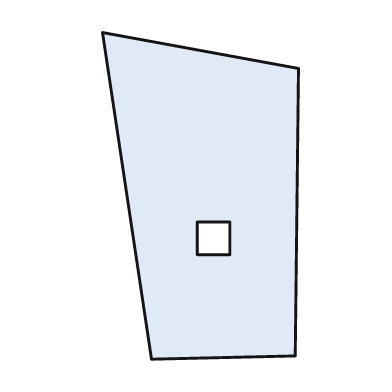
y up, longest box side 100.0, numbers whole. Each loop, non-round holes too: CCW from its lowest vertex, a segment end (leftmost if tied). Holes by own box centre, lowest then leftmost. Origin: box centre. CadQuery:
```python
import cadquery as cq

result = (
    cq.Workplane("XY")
    .moveTo(-15.0, -50.0)
    .lineTo(29.0, -49.0)
    .lineTo(30.0, 39.0)
    .lineTo(-30.0, 50.0)
    .close()
    .moveTo(-1.0, -18.0)
    .lineTo(9.0, -18.0)
    .lineTo(9.0, -8.0)
    .lineTo(-1.0, -8.0)
    .close()
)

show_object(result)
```